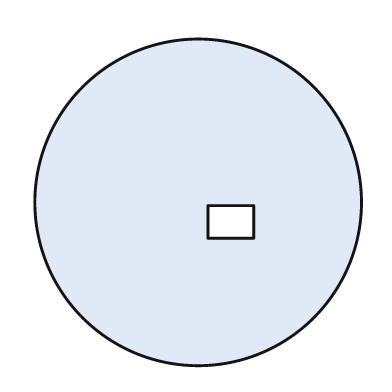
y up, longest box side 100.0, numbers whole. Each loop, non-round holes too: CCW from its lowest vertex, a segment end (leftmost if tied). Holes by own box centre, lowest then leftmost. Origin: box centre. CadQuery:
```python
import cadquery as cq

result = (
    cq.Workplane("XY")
    .moveTo(0.0, 0.0)
    .circle(50.0)
    .moveTo(3.0, -11.0)
    .lineTo(17.0, -11.0)
    .lineTo(17.0, -1.0)
    .lineTo(3.0, -1.0)
    .close()
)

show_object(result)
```